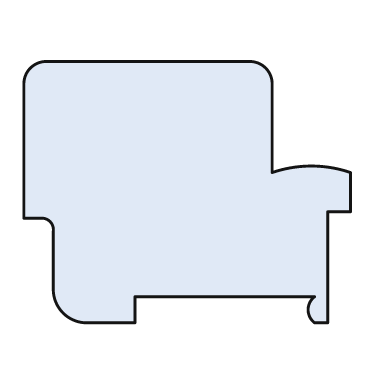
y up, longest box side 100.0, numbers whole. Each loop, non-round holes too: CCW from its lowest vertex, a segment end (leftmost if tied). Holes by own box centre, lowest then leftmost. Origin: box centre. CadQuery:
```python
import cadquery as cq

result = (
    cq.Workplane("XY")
    .moveTo(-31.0, -40.0)
    .lineTo(-16.0, -40.0)
    .lineTo(-16.0, -32.0)
    .lineTo(39.0, -32.0)
    .threePointArc((37.0, -36.0), (39.0, -40.0))
    .lineTo(43.0, -40.0)
    .lineTo(43.0, -6.0)
    .lineTo(50.0, -6.0)
    .lineTo(50.0, 6.0)
    .threePointArc((38.0, 8.0), (26.0, 6.0))
    .lineTo(26.0, 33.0)
    .threePointArc((24.0, 38.0), (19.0, 40.0))
    .lineTo(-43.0, 40.0)
    .threePointArc((-48.0, 38.0), (-50.0, 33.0))
    .lineTo(-50.0, -8.0)
    .lineTo(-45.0, -8.0)
    .threePointArc((-42.0, -9.0), (-41.0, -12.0))
    .lineTo(-41.0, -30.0)
    .threePointArc((-38.0, -37.0), (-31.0, -40.0))
    .close()
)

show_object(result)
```